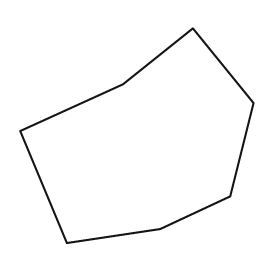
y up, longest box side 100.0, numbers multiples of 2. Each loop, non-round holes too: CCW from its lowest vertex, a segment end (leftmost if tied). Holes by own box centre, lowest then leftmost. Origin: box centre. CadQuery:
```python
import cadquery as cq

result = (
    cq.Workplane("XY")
    .moveTo(-30.0, -46.0)
    .lineTo(10.0, -40.0)
    .lineTo(40.0, -26.0)
    .lineTo(50.0, 14.0)
    .lineTo(24.0, 46.0)
    .lineTo(-6.0, 22.0)
    .lineTo(-50.0, 2.0)
    .close()
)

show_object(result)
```